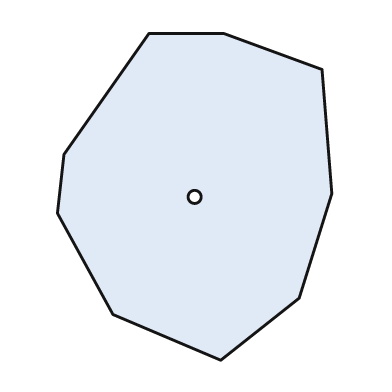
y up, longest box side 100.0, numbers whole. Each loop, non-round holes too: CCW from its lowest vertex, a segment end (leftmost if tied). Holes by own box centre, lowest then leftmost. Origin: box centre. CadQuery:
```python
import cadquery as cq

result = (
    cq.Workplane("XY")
    .moveTo(8.0, -50.0)
    .lineTo(32.0, -31.0)
    .lineTo(42.0, 1.0)
    .lineTo(39.0, 39.0)
    .lineTo(9.0, 50.0)
    .lineTo(-14.0, 50.0)
    .lineTo(-40.0, 13.0)
    .lineTo(-42.0, -5.0)
    .lineTo(-25.0, -36.0)
    .close()
    .moveTo(0.0, 0.0)
    .circle(2.0)
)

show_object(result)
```